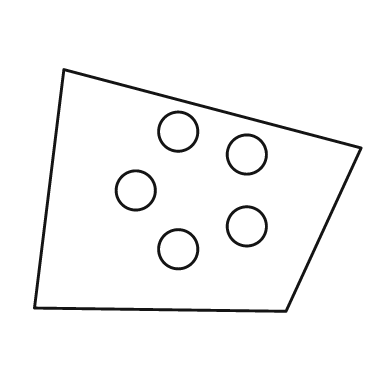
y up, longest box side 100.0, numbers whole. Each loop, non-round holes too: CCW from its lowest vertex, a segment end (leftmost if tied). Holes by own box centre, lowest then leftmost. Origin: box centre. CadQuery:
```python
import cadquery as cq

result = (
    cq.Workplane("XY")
    .moveTo(27.0, -37.0)
    .lineTo(50.0, 13.0)
    .lineTo(-41.0, 37.0)
    .lineTo(-50.0, -36.0)
    .close()
    .moveTo(-6.0, -18.0)
    .circle(6.0)
    .moveTo(15.0, -11.0)
    .circle(6.0)
    .moveTo(-19.0, 0.0)
    .circle(6.0)
    .moveTo(15.0, 11.0)
    .circle(6.0)
    .moveTo(-6.0, 18.0)
    .circle(6.0)
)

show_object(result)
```